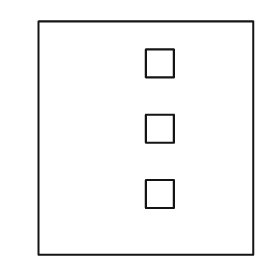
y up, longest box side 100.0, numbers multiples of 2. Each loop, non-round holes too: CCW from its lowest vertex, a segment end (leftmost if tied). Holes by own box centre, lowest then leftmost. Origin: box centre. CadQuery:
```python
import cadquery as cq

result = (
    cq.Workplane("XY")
    .moveTo(-46.0, -50.0)
    .lineTo(46.0, -50.0)
    .lineTo(46.0, 50.0)
    .lineTo(-46.0, 50.0)
    .close()
    .moveTo(0.0, -30.0)
    .lineTo(12.0, -30.0)
    .lineTo(12.0, -18.0)
    .lineTo(0.0, -18.0)
    .close()
    .moveTo(0.0, -2.0)
    .lineTo(12.0, -2.0)
    .lineTo(12.0, 10.0)
    .lineTo(0.0, 10.0)
    .close()
    .moveTo(0.0, 26.0)
    .lineTo(12.0, 26.0)
    .lineTo(12.0, 38.0)
    .lineTo(0.0, 38.0)
    .close()
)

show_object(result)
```